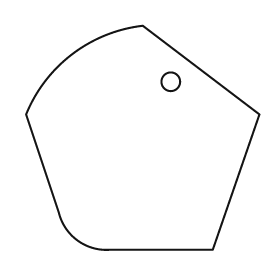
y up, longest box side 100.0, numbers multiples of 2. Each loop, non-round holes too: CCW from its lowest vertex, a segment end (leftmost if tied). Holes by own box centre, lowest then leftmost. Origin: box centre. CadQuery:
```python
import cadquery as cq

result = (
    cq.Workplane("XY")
    .moveTo(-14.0, -48.0)
    .lineTo(30.0, -48.0)
    .lineTo(50.0, 10.0)
    .lineTo(0.0, 48.0)
    .threePointArc((-30.0, 36.0), (-50.0, 10.0))
    .lineTo(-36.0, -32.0)
    .threePointArc((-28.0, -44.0), (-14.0, -48.0))
    .close()
    .moveTo(12.0, 24.0)
    .circle(4.0)
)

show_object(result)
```